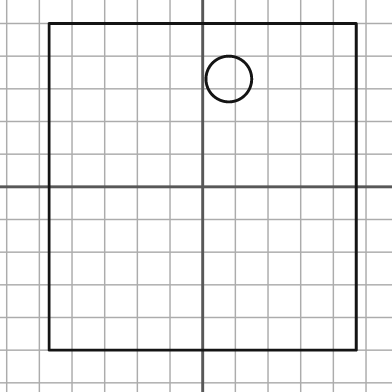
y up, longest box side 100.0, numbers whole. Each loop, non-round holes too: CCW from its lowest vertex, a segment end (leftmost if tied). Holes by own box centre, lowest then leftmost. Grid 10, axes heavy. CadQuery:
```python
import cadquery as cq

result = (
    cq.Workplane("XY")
    .moveTo(-47.0, -50.0)
    .lineTo(47.0, -50.0)
    .lineTo(47.0, 50.0)
    .lineTo(-47.0, 50.0)
    .close()
    .moveTo(8.0, 33.0)
    .circle(7.0)
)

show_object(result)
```